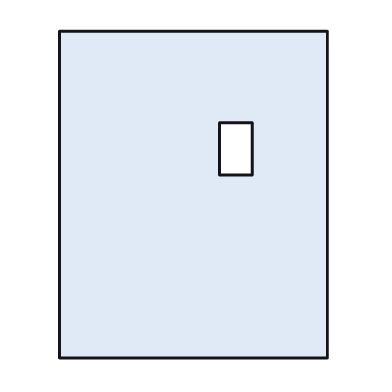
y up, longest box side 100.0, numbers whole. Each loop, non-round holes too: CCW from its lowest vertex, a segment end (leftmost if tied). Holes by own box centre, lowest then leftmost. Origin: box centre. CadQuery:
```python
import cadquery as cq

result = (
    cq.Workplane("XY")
    .moveTo(-41.0, -50.0)
    .lineTo(41.0, -50.0)
    .lineTo(41.0, 50.0)
    .lineTo(-41.0, 50.0)
    .close()
    .moveTo(8.0, 6.0)
    .lineTo(18.0, 6.0)
    .lineTo(18.0, 22.0)
    .lineTo(8.0, 22.0)
    .close()
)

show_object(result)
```